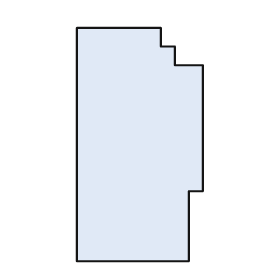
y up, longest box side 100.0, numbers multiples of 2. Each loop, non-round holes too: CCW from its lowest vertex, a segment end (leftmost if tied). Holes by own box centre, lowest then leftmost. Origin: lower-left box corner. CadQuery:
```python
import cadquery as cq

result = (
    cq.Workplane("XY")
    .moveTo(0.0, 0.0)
    .lineTo(48.0, 0.0)
    .lineTo(48.0, 30.0)
    .lineTo(54.0, 30.0)
    .lineTo(54.0, 84.0)
    .lineTo(42.0, 84.0)
    .lineTo(42.0, 92.0)
    .lineTo(36.0, 92.0)
    .lineTo(36.0, 100.0)
    .lineTo(0.0, 100.0)
    .close()
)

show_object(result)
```